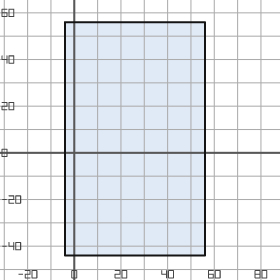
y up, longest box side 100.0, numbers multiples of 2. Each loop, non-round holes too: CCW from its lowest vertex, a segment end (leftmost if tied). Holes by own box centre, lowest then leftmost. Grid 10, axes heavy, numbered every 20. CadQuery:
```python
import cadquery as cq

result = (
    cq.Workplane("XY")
    .moveTo(-4.0, -44.0)
    .lineTo(56.0, -44.0)
    .lineTo(56.0, 56.0)
    .lineTo(-4.0, 56.0)
    .close()
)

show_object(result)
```